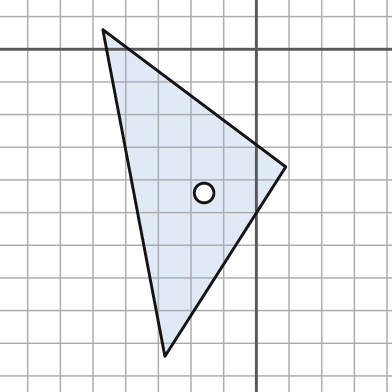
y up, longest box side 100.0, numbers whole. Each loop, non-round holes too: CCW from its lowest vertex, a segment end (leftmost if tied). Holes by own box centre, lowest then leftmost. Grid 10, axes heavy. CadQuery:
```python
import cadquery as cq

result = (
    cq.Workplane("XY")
    .moveTo(-28.0, -94.0)
    .lineTo(9.0, -36.0)
    .lineTo(-47.0, 6.0)
    .close()
    .moveTo(-16.0, -44.0)
    .circle(3.0)
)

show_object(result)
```